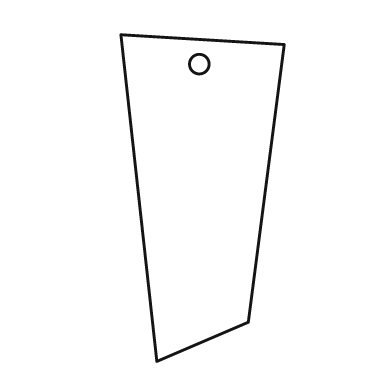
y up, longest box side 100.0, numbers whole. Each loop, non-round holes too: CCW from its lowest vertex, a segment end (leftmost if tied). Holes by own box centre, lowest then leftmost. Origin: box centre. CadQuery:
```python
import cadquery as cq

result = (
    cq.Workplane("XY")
    .moveTo(-14.0, -50.0)
    .lineTo(14.0, -38.0)
    .lineTo(25.0, 47.0)
    .lineTo(-25.0, 50.0)
    .close()
    .moveTo(-1.0, 41.0)
    .circle(3.0)
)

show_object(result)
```